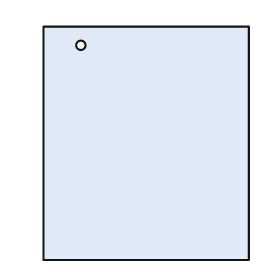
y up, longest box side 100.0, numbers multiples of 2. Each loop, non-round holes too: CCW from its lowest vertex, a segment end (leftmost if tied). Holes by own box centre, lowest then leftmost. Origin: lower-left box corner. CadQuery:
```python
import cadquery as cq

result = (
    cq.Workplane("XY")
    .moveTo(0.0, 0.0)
    .lineTo(88.0, 0.0)
    .lineTo(88.0, 100.0)
    .lineTo(0.0, 100.0)
    .close()
    .moveTo(16.0, 92.0)
    .circle(2.0)
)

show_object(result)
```